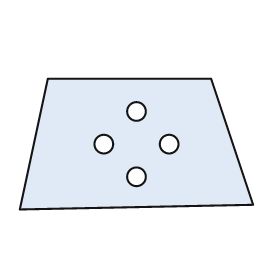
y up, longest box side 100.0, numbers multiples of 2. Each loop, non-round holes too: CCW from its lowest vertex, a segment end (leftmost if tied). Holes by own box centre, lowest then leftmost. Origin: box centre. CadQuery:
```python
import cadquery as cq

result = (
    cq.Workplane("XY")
    .moveTo(-50.0, -28.0)
    .lineTo(50.0, -26.0)
    .lineTo(32.0, 28.0)
    .lineTo(-38.0, 28.0)
    .close()
    .moveTo(0.0, -14.0)
    .circle(4.0)
    .moveTo(-14.0, 0.0)
    .circle(4.0)
    .moveTo(14.0, 0.0)
    .circle(4.0)
    .moveTo(0.0, 14.0)
    .circle(4.0)
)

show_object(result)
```